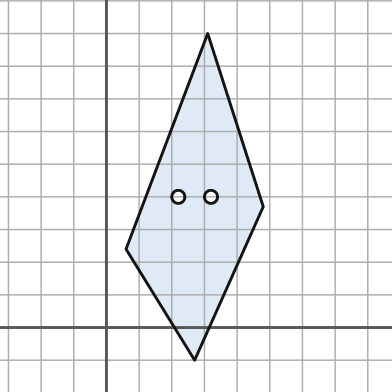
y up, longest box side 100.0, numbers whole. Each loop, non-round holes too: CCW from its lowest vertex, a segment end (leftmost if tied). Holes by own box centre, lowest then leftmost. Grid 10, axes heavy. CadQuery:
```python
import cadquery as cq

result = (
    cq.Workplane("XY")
    .moveTo(27.0, -10.0)
    .lineTo(48.0, 37.0)
    .lineTo(31.0, 90.0)
    .lineTo(6.0, 24.0)
    .close()
    .moveTo(22.0, 40.0)
    .circle(2.0)
    .moveTo(32.0, 40.0)
    .circle(2.0)
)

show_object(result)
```